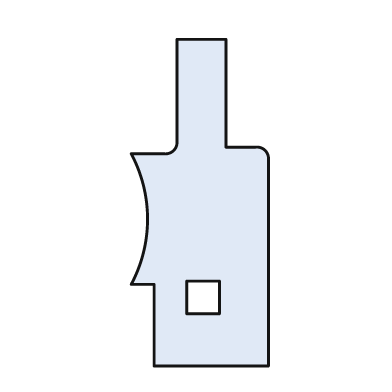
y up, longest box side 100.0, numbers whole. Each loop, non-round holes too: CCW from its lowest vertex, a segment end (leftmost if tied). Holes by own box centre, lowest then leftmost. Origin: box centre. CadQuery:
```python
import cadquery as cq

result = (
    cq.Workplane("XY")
    .moveTo(-14.0, -50.0)
    .lineTo(21.0, -50.0)
    .lineTo(21.0, 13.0)
    .threePointArc((20.0, 16.0), (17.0, 17.0))
    .lineTo(8.0, 17.0)
    .lineTo(8.0, 50.0)
    .lineTo(-7.0, 50.0)
    .lineTo(-7.0, 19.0)
    .threePointArc((-8.0, 16.0), (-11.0, 15.0))
    .lineTo(-21.0, 15.0)
    .threePointArc((-16.0, -5.0), (-21.0, -25.0))
    .lineTo(-14.0, -25.0)
    .close()
    .moveTo(-4.0, -34.0)
    .lineTo(6.0, -34.0)
    .lineTo(6.0, -24.0)
    .lineTo(-4.0, -24.0)
    .close()
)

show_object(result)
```